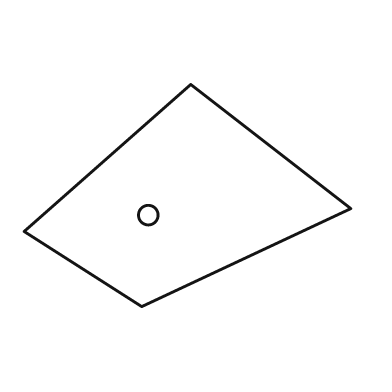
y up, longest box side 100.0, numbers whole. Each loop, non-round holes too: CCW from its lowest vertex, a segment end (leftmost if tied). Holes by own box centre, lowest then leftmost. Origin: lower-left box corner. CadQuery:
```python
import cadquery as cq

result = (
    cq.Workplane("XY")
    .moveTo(36.0, 0.0)
    .lineTo(100.0, 30.0)
    .lineTo(51.0, 68.0)
    .lineTo(0.0, 23.0)
    .close()
    .moveTo(38.0, 28.0)
    .circle(3.0)
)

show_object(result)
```